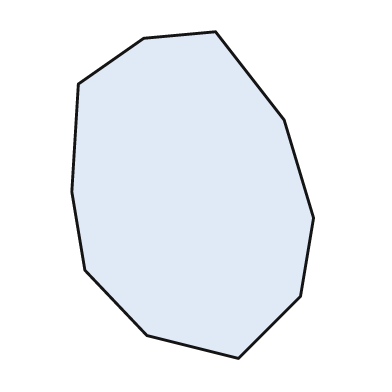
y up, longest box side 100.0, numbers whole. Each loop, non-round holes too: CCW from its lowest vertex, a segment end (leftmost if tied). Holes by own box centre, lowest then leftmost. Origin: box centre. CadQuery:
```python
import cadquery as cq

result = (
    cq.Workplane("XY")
    .moveTo(14.0, -50.0)
    .lineTo(33.0, -31.0)
    .lineTo(37.0, -7.0)
    .lineTo(28.0, 23.0)
    .lineTo(7.0, 50.0)
    .lineTo(-15.0, 48.0)
    .lineTo(-35.0, 34.0)
    .lineTo(-37.0, 1.0)
    .lineTo(-33.0, -23.0)
    .lineTo(-14.0, -43.0)
    .close()
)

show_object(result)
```